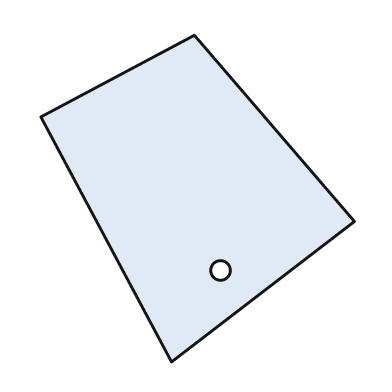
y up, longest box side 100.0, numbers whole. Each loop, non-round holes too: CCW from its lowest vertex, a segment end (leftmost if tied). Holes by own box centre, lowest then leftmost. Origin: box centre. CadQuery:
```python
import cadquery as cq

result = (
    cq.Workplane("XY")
    .moveTo(-8.0, -50.0)
    .lineTo(48.0, -7.0)
    .lineTo(-1.0, 50.0)
    .lineTo(-48.0, 25.0)
    .close()
    .moveTo(7.0, -22.0)
    .circle(3.0)
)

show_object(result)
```